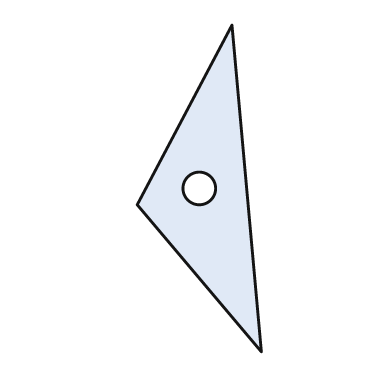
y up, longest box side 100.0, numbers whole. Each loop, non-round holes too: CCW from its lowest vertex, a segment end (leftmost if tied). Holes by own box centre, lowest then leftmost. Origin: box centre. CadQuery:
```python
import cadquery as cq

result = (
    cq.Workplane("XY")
    .moveTo(19.0, -50.0)
    .lineTo(10.0, 50.0)
    .lineTo(-19.0, -5.0)
    .close()
    .moveTo(0.0, 0.0)
    .circle(5.0)
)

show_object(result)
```